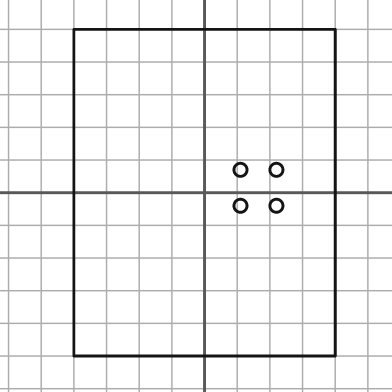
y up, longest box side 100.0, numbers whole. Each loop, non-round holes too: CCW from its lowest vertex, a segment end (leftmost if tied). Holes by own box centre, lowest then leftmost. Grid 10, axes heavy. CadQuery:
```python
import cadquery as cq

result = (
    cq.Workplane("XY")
    .moveTo(-40.0, -50.0)
    .lineTo(40.0, -50.0)
    .lineTo(40.0, 50.0)
    .lineTo(-40.0, 50.0)
    .close()
    .moveTo(11.0, -4.0)
    .circle(2.0)
    .moveTo(22.0, -4.0)
    .circle(2.0)
    .moveTo(11.0, 7.0)
    .circle(2.0)
    .moveTo(22.0, 7.0)
    .circle(2.0)
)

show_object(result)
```